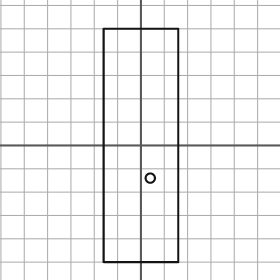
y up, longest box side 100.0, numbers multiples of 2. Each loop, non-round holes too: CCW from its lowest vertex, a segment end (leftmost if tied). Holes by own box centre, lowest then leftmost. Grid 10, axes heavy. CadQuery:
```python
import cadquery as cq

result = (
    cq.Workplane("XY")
    .moveTo(-16.0, -50.0)
    .lineTo(16.0, -50.0)
    .lineTo(16.0, 50.0)
    .lineTo(-16.0, 50.0)
    .close()
    .moveTo(4.0, -14.0)
    .circle(2.0)
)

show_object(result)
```